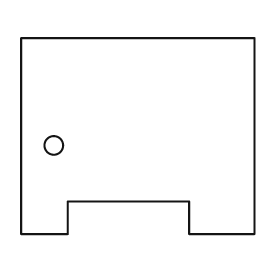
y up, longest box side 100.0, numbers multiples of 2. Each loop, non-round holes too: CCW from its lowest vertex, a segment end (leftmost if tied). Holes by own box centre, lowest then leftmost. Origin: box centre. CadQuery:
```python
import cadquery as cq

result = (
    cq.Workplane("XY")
    .moveTo(-50.0, -42.0)
    .lineTo(-30.0, -42.0)
    .lineTo(-30.0, -28.0)
    .lineTo(22.0, -28.0)
    .lineTo(22.0, -42.0)
    .lineTo(50.0, -42.0)
    .lineTo(50.0, 42.0)
    .lineTo(-50.0, 42.0)
    .close()
    .moveTo(-36.0, -4.0)
    .circle(4.0)
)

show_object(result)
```